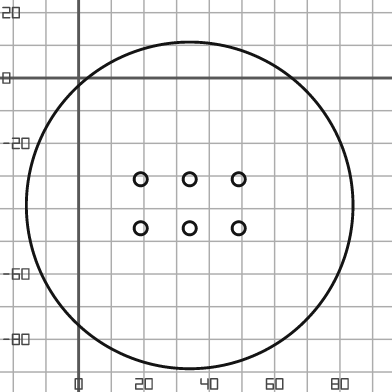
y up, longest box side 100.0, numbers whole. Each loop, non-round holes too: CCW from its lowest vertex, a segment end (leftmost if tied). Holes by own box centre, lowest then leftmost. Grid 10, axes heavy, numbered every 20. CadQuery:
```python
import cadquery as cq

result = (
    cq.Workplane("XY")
    .moveTo(34.0, -39.0)
    .circle(50.0)
    .moveTo(19.0, -46.0)
    .circle(2.0)
    .moveTo(34.0, -46.0)
    .circle(2.0)
    .moveTo(49.0, -46.0)
    .circle(2.0)
    .moveTo(19.0, -31.0)
    .circle(2.0)
    .moveTo(34.0, -31.0)
    .circle(2.0)
    .moveTo(49.0, -31.0)
    .circle(2.0)
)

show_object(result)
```